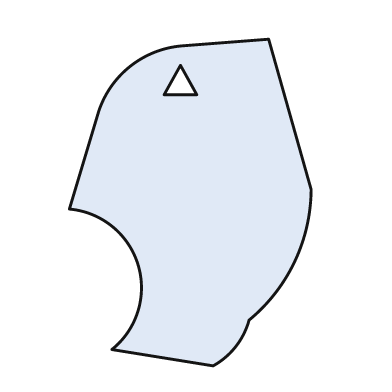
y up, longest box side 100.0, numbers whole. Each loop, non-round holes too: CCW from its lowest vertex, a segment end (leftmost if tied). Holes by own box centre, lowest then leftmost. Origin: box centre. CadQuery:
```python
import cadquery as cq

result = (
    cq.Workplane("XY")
    .moveTo(7.0, -50.0)
    .threePointArc((14.0, -44.0), (18.0, -36.0))
    .threePointArc((32.0, -18.0), (37.0, 4.0))
    .lineTo(24.0, 50.0)
    .lineTo(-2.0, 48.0)
    .threePointArc((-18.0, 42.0), (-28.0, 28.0))
    .lineTo(-37.0, -2.0)
    .threePointArc((-16.0, -19.0), (-24.0, -45.0))
    .close()
    .moveTo(-8.0, 33.0)
    .lineTo(2.0, 33.0)
    .lineTo(-3.0, 42.0)
    .close()
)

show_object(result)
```